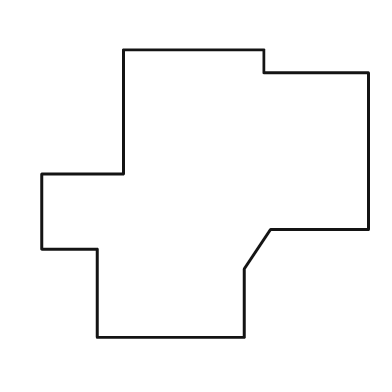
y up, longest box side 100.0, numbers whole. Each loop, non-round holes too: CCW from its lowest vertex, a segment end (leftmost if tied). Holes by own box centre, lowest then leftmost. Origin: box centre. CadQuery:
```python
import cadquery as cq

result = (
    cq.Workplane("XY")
    .moveTo(-33.0, -44.0)
    .lineTo(12.0, -44.0)
    .lineTo(12.0, -23.0)
    .lineTo(20.0, -11.0)
    .lineTo(50.0, -11.0)
    .lineTo(50.0, 37.0)
    .lineTo(18.0, 37.0)
    .lineTo(18.0, 44.0)
    .lineTo(-25.0, 44.0)
    .lineTo(-25.0, 6.0)
    .lineTo(-50.0, 6.0)
    .lineTo(-50.0, -17.0)
    .lineTo(-33.0, -17.0)
    .close()
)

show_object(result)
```